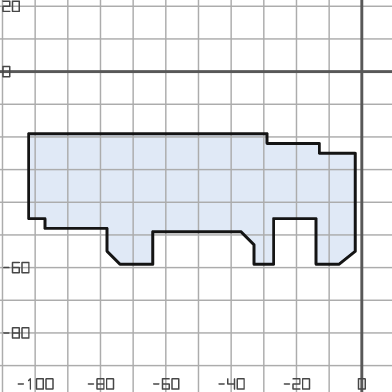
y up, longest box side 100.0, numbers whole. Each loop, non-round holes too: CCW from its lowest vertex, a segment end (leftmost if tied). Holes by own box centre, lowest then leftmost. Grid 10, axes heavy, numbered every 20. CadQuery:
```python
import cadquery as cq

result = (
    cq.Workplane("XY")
    .moveTo(-74.0, -59.0)
    .lineTo(-64.0, -59.0)
    .lineTo(-64.0, -49.0)
    .lineTo(-37.0, -49.0)
    .lineTo(-33.0, -53.0)
    .lineTo(-33.0, -59.0)
    .lineTo(-27.0, -59.0)
    .lineTo(-27.0, -45.0)
    .lineTo(-14.0, -45.0)
    .lineTo(-14.0, -59.0)
    .lineTo(-7.0, -59.0)
    .lineTo(-2.0, -55.0)
    .lineTo(-2.0, -25.0)
    .lineTo(-13.0, -25.0)
    .lineTo(-13.0, -22.0)
    .lineTo(-29.0, -22.0)
    .lineTo(-29.0, -19.0)
    .lineTo(-102.0, -19.0)
    .lineTo(-102.0, -45.0)
    .lineTo(-97.0, -45.0)
    .lineTo(-97.0, -48.0)
    .lineTo(-78.0, -48.0)
    .lineTo(-78.0, -55.0)
    .close()
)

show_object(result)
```